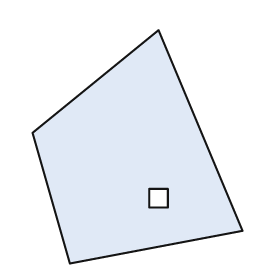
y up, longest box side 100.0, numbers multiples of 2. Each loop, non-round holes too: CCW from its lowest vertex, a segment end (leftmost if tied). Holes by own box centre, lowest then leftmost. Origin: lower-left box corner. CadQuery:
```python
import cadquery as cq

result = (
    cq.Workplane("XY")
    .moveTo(16.0, 0.0)
    .lineTo(90.0, 14.0)
    .lineTo(54.0, 100.0)
    .lineTo(0.0, 56.0)
    .close()
    .moveTo(50.0, 24.0)
    .lineTo(58.0, 24.0)
    .lineTo(58.0, 32.0)
    .lineTo(50.0, 32.0)
    .close()
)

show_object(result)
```